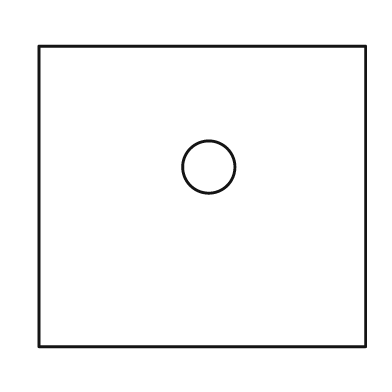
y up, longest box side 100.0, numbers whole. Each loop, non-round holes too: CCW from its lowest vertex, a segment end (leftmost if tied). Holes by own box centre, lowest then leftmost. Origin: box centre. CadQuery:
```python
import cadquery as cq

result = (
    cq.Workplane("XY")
    .moveTo(-50.0, -46.0)
    .lineTo(50.0, -46.0)
    .lineTo(50.0, 46.0)
    .lineTo(-50.0, 46.0)
    .close()
    .moveTo(2.0, 9.0)
    .circle(8.0)
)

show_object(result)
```